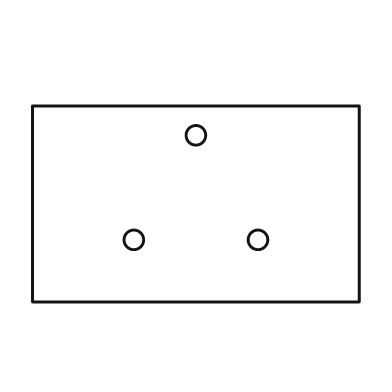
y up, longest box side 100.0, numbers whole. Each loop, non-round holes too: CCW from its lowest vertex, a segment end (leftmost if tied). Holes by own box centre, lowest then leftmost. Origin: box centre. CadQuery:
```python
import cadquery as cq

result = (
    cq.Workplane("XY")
    .moveTo(-50.0, -30.0)
    .lineTo(50.0, -30.0)
    .lineTo(50.0, 30.0)
    .lineTo(-50.0, 30.0)
    .close()
    .moveTo(-19.0, -11.0)
    .circle(3.0)
    .moveTo(19.0, -11.0)
    .circle(3.0)
    .moveTo(0.0, 21.0)
    .circle(3.0)
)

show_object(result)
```